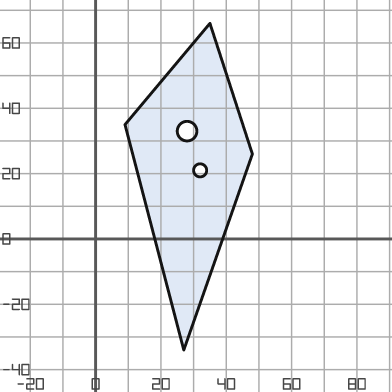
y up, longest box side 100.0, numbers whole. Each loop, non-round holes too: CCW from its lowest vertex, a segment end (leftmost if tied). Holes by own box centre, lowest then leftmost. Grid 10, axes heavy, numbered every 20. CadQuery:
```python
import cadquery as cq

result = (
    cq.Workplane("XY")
    .moveTo(27.0, -34.0)
    .lineTo(48.0, 26.0)
    .lineTo(35.0, 66.0)
    .lineTo(9.0, 35.0)
    .close()
    .moveTo(32.0, 21.0)
    .circle(2.0)
    .moveTo(28.0, 33.0)
    .circle(3.0)
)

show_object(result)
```